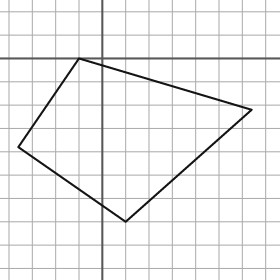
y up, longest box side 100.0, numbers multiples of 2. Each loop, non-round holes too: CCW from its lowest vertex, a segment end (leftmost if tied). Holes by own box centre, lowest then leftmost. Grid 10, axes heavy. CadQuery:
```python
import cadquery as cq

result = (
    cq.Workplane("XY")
    .moveTo(10.0, -70.0)
    .lineTo(64.0, -22.0)
    .lineTo(-10.0, 0.0)
    .lineTo(-36.0, -38.0)
    .close()
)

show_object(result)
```